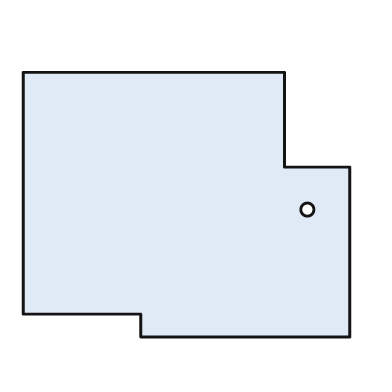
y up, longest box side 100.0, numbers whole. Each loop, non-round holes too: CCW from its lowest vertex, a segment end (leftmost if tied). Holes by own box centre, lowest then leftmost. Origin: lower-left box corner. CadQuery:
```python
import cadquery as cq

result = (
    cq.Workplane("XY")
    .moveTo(36.0, 0.0)
    .lineTo(100.0, 0.0)
    .lineTo(100.0, 52.0)
    .lineTo(80.0, 52.0)
    .lineTo(80.0, 81.0)
    .lineTo(0.0, 81.0)
    .lineTo(0.0, 7.0)
    .lineTo(36.0, 7.0)
    .close()
    .moveTo(87.0, 39.0)
    .circle(2.0)
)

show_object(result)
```